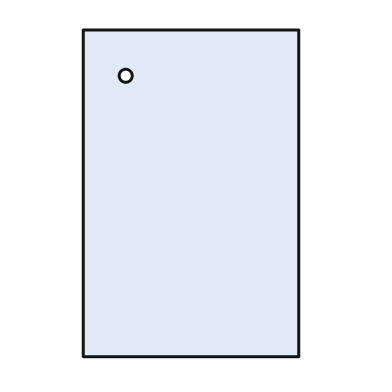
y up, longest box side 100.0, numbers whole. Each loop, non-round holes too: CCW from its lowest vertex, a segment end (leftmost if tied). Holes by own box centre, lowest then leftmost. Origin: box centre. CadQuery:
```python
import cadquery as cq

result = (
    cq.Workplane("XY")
    .moveTo(-33.0, -50.0)
    .lineTo(33.0, -50.0)
    .lineTo(33.0, 50.0)
    .lineTo(-33.0, 50.0)
    .close()
    .moveTo(-20.0, 36.0)
    .circle(2.0)
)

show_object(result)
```